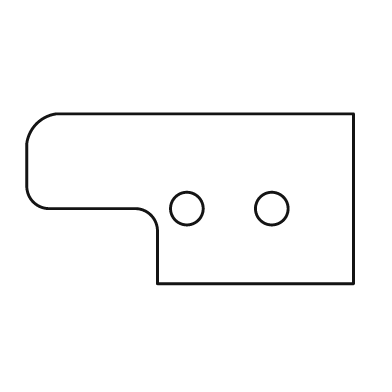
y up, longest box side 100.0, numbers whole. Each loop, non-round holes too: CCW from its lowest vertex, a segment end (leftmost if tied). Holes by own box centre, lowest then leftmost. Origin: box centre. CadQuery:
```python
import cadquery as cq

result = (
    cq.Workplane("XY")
    .moveTo(-10.0, -26.0)
    .lineTo(50.0, -26.0)
    .lineTo(50.0, 26.0)
    .lineTo(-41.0, 26.0)
    .threePointArc((-47.0, 23.0), (-50.0, 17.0))
    .lineTo(-50.0, 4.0)
    .threePointArc((-48.0, -1.0), (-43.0, -3.0))
    .lineTo(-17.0, -3.0)
    .threePointArc((-12.0, -5.0), (-10.0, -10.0))
    .close()
    .moveTo(-1.0, -3.0)
    .circle(5.0)
    .moveTo(25.0, -3.0)
    .circle(5.0)
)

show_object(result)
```